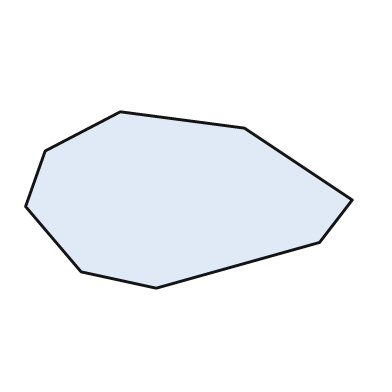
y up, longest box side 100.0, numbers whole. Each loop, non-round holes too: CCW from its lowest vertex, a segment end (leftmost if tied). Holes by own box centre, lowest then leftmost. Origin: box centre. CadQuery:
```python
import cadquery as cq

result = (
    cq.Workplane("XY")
    .moveTo(-10.0, -27.0)
    .lineTo(40.0, -13.0)
    .lineTo(50.0, 0.0)
    .lineTo(17.0, 22.0)
    .lineTo(-21.0, 27.0)
    .lineTo(-44.0, 15.0)
    .lineTo(-50.0, -2.0)
    .lineTo(-33.0, -22.0)
    .close()
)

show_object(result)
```